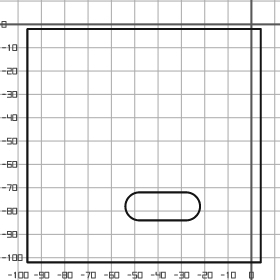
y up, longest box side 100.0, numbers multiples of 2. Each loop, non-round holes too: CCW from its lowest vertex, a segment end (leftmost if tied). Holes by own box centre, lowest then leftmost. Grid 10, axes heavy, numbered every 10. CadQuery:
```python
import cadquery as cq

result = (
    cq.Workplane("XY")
    .moveTo(-96.0, -102.0)
    .lineTo(4.0, -102.0)
    .lineTo(4.0, -2.0)
    .lineTo(-96.0, -2.0)
    .close()
    .moveTo(-48.0, -84.0)
    .lineTo(-28.0, -84.0)
    .threePointArc((-22.0, -78.0), (-28.0, -72.0))
    .lineTo(-48.0, -72.0)
    .threePointArc((-54.0, -78.0), (-48.0, -84.0))
    .close()
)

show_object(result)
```